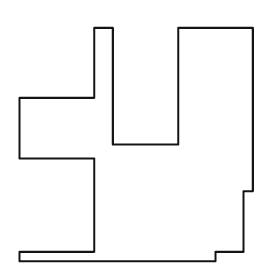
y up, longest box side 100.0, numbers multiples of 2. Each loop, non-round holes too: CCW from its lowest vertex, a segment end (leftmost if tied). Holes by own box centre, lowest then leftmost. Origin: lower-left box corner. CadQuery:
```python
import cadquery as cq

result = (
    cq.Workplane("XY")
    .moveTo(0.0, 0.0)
    .lineTo(84.0, 0.0)
    .lineTo(84.0, 4.0)
    .lineTo(96.0, 4.0)
    .lineTo(96.0, 30.0)
    .lineTo(100.0, 30.0)
    .lineTo(100.0, 100.0)
    .lineTo(68.0, 100.0)
    .lineTo(68.0, 50.0)
    .lineTo(40.0, 50.0)
    .lineTo(40.0, 100.0)
    .lineTo(32.0, 100.0)
    .lineTo(32.0, 70.0)
    .lineTo(0.0, 70.0)
    .lineTo(0.0, 44.0)
    .lineTo(32.0, 44.0)
    .lineTo(32.0, 4.0)
    .lineTo(0.0, 4.0)
    .close()
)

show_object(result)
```